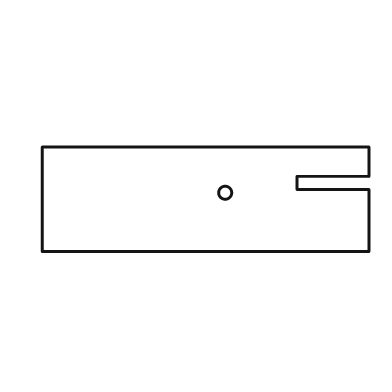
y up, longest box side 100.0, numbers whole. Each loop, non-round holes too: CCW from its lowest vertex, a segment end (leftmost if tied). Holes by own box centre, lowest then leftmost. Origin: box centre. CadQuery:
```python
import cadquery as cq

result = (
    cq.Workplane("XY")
    .moveTo(-50.0, -16.0)
    .lineTo(50.0, -16.0)
    .lineTo(50.0, 3.0)
    .lineTo(28.0, 3.0)
    .lineTo(28.0, 7.0)
    .lineTo(50.0, 7.0)
    .lineTo(50.0, 16.0)
    .lineTo(-50.0, 16.0)
    .close()
    .moveTo(6.0, 2.0)
    .circle(2.0)
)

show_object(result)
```